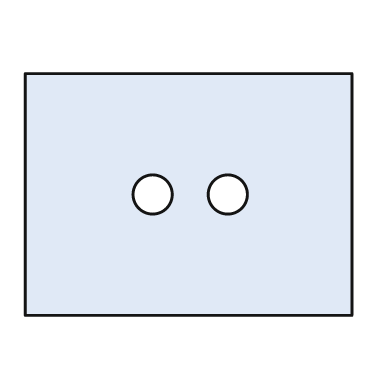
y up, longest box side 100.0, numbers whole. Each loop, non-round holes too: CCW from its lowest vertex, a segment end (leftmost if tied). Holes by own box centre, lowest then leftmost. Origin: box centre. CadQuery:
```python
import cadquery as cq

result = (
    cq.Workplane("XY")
    .moveTo(-50.0, -37.0)
    .lineTo(50.0, -37.0)
    .lineTo(50.0, 37.0)
    .lineTo(-50.0, 37.0)
    .close()
    .moveTo(-11.0, 0.0)
    .circle(6.0)
    .moveTo(12.0, 0.0)
    .circle(6.0)
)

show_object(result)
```